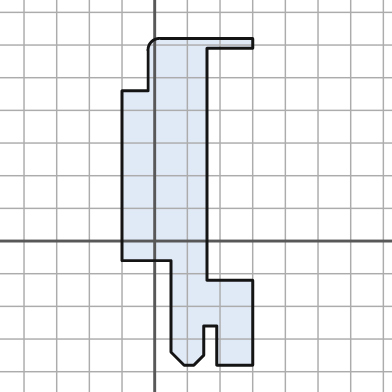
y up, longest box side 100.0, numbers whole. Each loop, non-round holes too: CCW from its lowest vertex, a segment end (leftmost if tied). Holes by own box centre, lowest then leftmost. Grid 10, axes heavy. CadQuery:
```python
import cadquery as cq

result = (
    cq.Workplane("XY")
    .moveTo(9.0, -38.0)
    .lineTo(12.0, -38.0)
    .lineTo(15.0, -35.0)
    .lineTo(15.0, -26.0)
    .lineTo(19.0, -26.0)
    .lineTo(19.0, -38.0)
    .lineTo(30.0, -38.0)
    .lineTo(30.0, -12.0)
    .lineTo(16.0, -12.0)
    .lineTo(16.0, 59.0)
    .lineTo(30.0, 59.0)
    .lineTo(30.0, 62.0)
    .lineTo(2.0, 62.0)
    .threePointArc((-1.0, 61.0), (-2.0, 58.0))
    .lineTo(-2.0, 46.0)
    .lineTo(-10.0, 46.0)
    .lineTo(-10.0, -6.0)
    .lineTo(5.0, -6.0)
    .lineTo(5.0, -34.0)
    .close()
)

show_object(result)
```